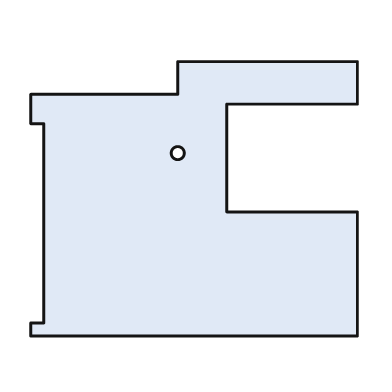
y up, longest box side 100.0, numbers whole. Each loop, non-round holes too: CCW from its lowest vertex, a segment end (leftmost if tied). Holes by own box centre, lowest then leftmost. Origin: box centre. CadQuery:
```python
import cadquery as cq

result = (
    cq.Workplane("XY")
    .moveTo(-50.0, -42.0)
    .lineTo(50.0, -42.0)
    .lineTo(50.0, -4.0)
    .lineTo(10.0, -4.0)
    .lineTo(10.0, 29.0)
    .lineTo(50.0, 29.0)
    .lineTo(50.0, 42.0)
    .lineTo(-5.0, 42.0)
    .lineTo(-5.0, 32.0)
    .lineTo(-50.0, 32.0)
    .lineTo(-50.0, 23.0)
    .lineTo(-46.0, 23.0)
    .lineTo(-46.0, -38.0)
    .lineTo(-50.0, -38.0)
    .close()
    .moveTo(-5.0, 14.0)
    .circle(2.0)
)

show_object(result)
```